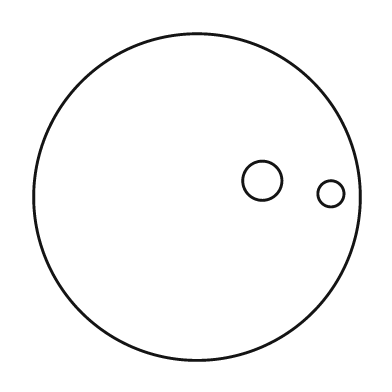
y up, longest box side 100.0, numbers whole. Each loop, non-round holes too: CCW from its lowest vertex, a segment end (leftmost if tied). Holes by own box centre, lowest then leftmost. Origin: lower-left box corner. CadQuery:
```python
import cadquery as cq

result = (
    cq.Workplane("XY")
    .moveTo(50.0, 50.0)
    .circle(50.0)
    .moveTo(91.0, 51.0)
    .circle(4.0)
    .moveTo(70.0, 55.0)
    .circle(6.0)
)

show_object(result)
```